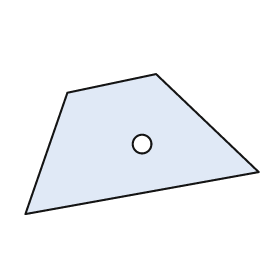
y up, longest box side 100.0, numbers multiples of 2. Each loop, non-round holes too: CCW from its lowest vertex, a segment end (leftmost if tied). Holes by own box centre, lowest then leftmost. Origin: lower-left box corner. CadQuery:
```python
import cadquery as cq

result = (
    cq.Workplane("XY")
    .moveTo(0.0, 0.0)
    .lineTo(100.0, 18.0)
    .lineTo(56.0, 60.0)
    .lineTo(18.0, 52.0)
    .close()
    .moveTo(50.0, 30.0)
    .circle(4.0)
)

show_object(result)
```